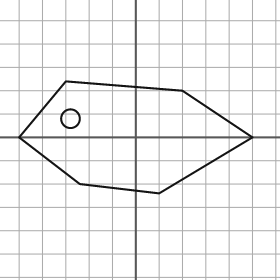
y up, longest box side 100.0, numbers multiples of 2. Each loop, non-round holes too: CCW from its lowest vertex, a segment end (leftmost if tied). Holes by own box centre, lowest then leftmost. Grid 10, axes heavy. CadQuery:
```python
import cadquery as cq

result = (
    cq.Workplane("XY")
    .moveTo(10.0, -24.0)
    .lineTo(50.0, 0.0)
    .lineTo(20.0, 20.0)
    .lineTo(-30.0, 24.0)
    .lineTo(-50.0, 0.0)
    .lineTo(-24.0, -20.0)
    .close()
    .moveTo(-28.0, 8.0)
    .circle(4.0)
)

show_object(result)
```